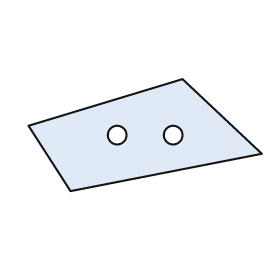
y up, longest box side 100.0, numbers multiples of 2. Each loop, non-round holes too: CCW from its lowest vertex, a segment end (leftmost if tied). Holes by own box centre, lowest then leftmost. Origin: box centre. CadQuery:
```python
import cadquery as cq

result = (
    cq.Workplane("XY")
    .moveTo(-32.0, -24.0)
    .lineTo(50.0, -8.0)
    .lineTo(16.0, 24.0)
    .lineTo(-50.0, 4.0)
    .close()
    .moveTo(-12.0, 0.0)
    .circle(4.0)
    .moveTo(12.0, 0.0)
    .circle(4.0)
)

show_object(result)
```